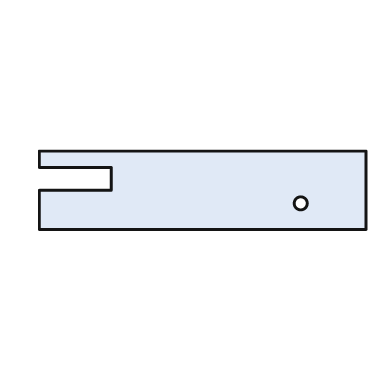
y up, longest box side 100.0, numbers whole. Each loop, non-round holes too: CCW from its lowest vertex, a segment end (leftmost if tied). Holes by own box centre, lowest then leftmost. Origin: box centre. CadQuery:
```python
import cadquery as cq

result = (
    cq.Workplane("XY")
    .moveTo(-50.0, -12.0)
    .lineTo(50.0, -12.0)
    .lineTo(50.0, 12.0)
    .lineTo(-50.0, 12.0)
    .lineTo(-50.0, 7.0)
    .lineTo(-28.0, 7.0)
    .lineTo(-28.0, 0.0)
    .lineTo(-50.0, 0.0)
    .close()
    .moveTo(30.0, -4.0)
    .circle(2.0)
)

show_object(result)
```